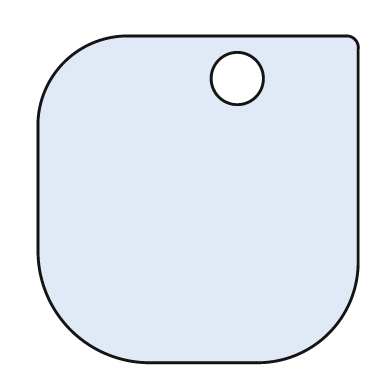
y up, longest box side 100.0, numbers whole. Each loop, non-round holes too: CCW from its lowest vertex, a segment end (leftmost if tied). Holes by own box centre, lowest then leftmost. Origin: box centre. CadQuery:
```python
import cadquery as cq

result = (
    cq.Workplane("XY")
    .moveTo(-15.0, -50.0)
    .lineTo(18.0, -50.0)
    .threePointArc((40.0, -41.0), (49.0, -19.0))
    .lineTo(49.0, 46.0)
    .threePointArc((48.0, 49.0), (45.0, 50.0))
    .lineTo(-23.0, 50.0)
    .threePointArc((-41.0, 42.0), (-49.0, 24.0))
    .lineTo(-49.0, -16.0)
    .threePointArc((-39.0, -40.0), (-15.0, -50.0))
    .close()
    .moveTo(12.0, 37.0)
    .circle(8.0)
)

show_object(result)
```